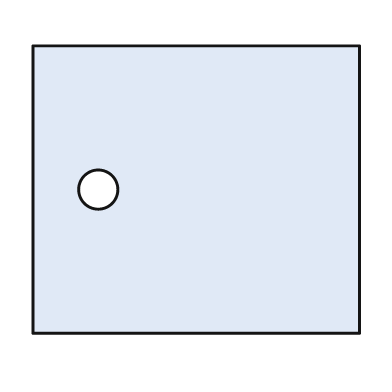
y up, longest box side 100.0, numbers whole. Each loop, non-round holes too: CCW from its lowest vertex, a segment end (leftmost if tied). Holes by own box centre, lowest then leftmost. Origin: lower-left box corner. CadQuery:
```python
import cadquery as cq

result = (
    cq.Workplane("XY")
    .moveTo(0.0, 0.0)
    .lineTo(100.0, 0.0)
    .lineTo(100.0, 88.0)
    .lineTo(0.0, 88.0)
    .close()
    .moveTo(20.0, 44.0)
    .circle(6.0)
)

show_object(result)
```